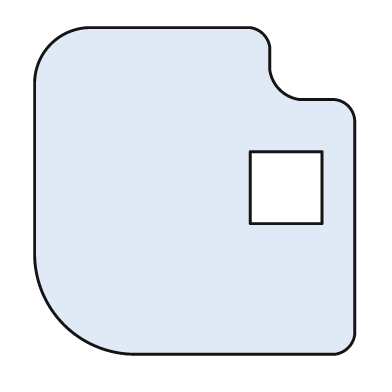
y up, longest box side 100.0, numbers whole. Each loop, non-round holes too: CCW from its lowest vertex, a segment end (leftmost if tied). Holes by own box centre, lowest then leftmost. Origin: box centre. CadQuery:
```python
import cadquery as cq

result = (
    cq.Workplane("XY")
    .moveTo(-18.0, -50.0)
    .lineTo(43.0, -50.0)
    .threePointArc((47.0, -48.0), (49.0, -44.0))
    .lineTo(49.0, 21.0)
    .threePointArc((47.0, 26.0), (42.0, 28.0))
    .lineTo(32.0, 28.0)
    .threePointArc((26.0, 31.0), (23.0, 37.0))
    .lineTo(23.0, 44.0)
    .threePointArc((21.0, 48.0), (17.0, 50.0))
    .lineTo(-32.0, 50.0)
    .threePointArc((-44.0, 45.0), (-49.0, 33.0))
    .lineTo(-49.0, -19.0)
    .threePointArc((-40.0, -41.0), (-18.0, -50.0))
    .close()
    .moveTo(17.0, -10.0)
    .lineTo(39.0, -10.0)
    .lineTo(39.0, 12.0)
    .lineTo(17.0, 12.0)
    .close()
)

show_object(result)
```